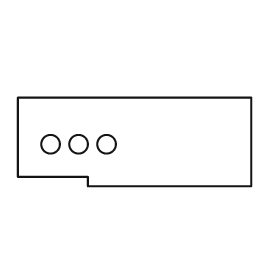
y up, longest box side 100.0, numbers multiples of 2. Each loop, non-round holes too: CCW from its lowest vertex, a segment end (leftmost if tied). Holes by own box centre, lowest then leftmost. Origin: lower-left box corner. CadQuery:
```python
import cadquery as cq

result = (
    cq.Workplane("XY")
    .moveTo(30.0, 0.0)
    .lineTo(100.0, 0.0)
    .lineTo(100.0, 38.0)
    .lineTo(0.0, 38.0)
    .lineTo(0.0, 4.0)
    .lineTo(30.0, 4.0)
    .close()
    .moveTo(14.0, 18.0)
    .circle(4.0)
    .moveTo(26.0, 18.0)
    .circle(4.0)
    .moveTo(38.0, 18.0)
    .circle(4.0)
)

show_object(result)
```